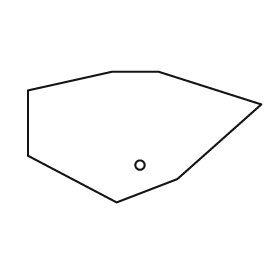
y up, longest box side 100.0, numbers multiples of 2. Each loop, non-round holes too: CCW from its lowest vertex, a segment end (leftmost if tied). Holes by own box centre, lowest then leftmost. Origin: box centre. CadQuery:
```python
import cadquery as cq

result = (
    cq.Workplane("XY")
    .moveTo(-12.0, -28.0)
    .lineTo(14.0, -18.0)
    .lineTo(50.0, 14.0)
    .lineTo(6.0, 28.0)
    .lineTo(-14.0, 28.0)
    .lineTo(-50.0, 20.0)
    .lineTo(-50.0, -8.0)
    .close()
    .moveTo(-2.0, -12.0)
    .circle(2.0)
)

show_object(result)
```